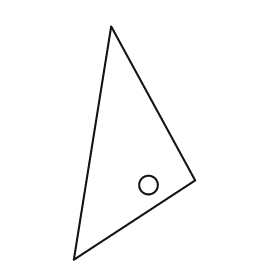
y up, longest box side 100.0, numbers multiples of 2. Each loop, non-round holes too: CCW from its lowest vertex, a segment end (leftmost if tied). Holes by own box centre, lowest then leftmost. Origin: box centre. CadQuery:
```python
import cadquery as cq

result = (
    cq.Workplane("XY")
    .moveTo(-26.0, -50.0)
    .lineTo(26.0, -16.0)
    .lineTo(-10.0, 50.0)
    .close()
    .moveTo(6.0, -18.0)
    .circle(4.0)
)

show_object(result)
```